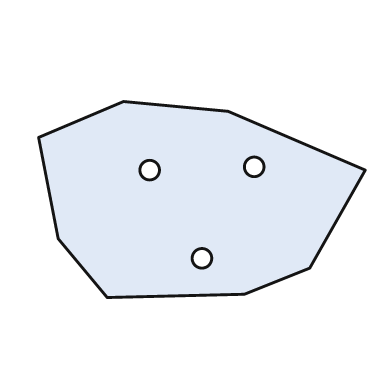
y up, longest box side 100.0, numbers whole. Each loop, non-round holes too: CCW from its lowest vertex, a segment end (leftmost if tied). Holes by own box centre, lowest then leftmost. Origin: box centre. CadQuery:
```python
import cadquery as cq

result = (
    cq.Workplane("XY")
    .moveTo(-29.0, -30.0)
    .lineTo(13.0, -29.0)
    .lineTo(33.0, -21.0)
    .lineTo(50.0, 9.0)
    .lineTo(8.0, 27.0)
    .lineTo(-24.0, 30.0)
    .lineTo(-50.0, 19.0)
    .lineTo(-44.0, -12.0)
    .close()
    .moveTo(0.0, -18.0)
    .circle(3.0)
    .moveTo(-16.0, 9.0)
    .circle(3.0)
    .moveTo(16.0, 10.0)
    .circle(3.0)
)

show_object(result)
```